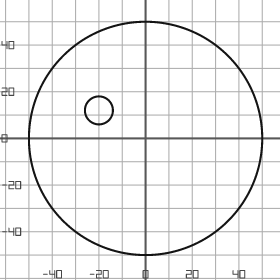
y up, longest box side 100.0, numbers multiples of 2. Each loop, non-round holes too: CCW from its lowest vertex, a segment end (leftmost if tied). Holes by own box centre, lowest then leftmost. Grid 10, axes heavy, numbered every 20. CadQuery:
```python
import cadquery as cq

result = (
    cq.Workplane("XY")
    .moveTo(0.0, 0.0)
    .circle(50.0)
    .moveTo(-20.0, 12.0)
    .circle(6.0)
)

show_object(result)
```